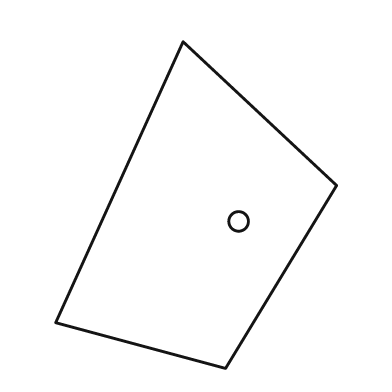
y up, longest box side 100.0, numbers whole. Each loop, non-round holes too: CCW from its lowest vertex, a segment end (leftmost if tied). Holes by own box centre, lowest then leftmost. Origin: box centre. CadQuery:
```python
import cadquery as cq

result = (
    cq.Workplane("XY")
    .moveTo(9.0, -50.0)
    .lineTo(43.0, 6.0)
    .lineTo(-4.0, 50.0)
    .lineTo(-43.0, -36.0)
    .close()
    .moveTo(13.0, -5.0)
    .circle(3.0)
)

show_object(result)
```